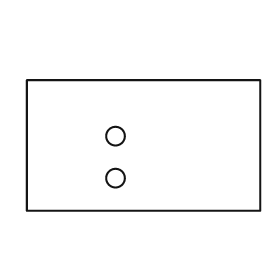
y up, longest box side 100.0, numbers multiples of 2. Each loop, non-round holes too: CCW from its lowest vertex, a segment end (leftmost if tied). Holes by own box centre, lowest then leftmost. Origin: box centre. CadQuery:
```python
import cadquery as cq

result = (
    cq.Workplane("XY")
    .moveTo(-50.0, -28.0)
    .lineTo(50.0, -28.0)
    .lineTo(50.0, 28.0)
    .lineTo(-50.0, 28.0)
    .close()
    .moveTo(-12.0, -14.0)
    .circle(4.0)
    .moveTo(-12.0, 4.0)
    .circle(4.0)
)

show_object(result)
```